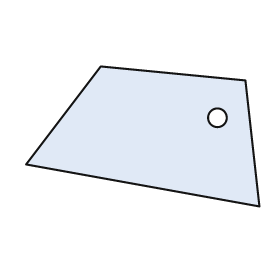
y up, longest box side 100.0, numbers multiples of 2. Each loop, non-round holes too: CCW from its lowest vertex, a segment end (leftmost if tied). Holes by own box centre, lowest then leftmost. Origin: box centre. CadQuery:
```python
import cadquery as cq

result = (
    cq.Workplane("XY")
    .moveTo(50.0, -30.0)
    .lineTo(44.0, 24.0)
    .lineTo(-18.0, 30.0)
    .lineTo(-50.0, -12.0)
    .close()
    .moveTo(32.0, 8.0)
    .circle(4.0)
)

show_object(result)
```